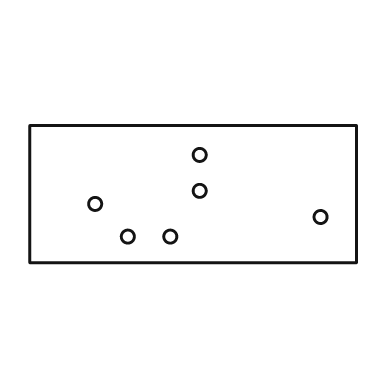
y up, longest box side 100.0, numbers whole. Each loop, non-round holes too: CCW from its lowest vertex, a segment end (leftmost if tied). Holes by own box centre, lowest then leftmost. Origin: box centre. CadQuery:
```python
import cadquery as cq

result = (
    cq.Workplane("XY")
    .moveTo(-50.0, -21.0)
    .lineTo(50.0, -21.0)
    .lineTo(50.0, 21.0)
    .lineTo(-50.0, 21.0)
    .close()
    .moveTo(-20.0, -13.0)
    .circle(2.0)
    .moveTo(-7.0, -13.0)
    .circle(2.0)
    .moveTo(39.0, -7.0)
    .circle(2.0)
    .moveTo(-30.0, -3.0)
    .circle(2.0)
    .moveTo(2.0, 1.0)
    .circle(2.0)
    .moveTo(2.0, 12.0)
    .circle(2.0)
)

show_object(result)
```